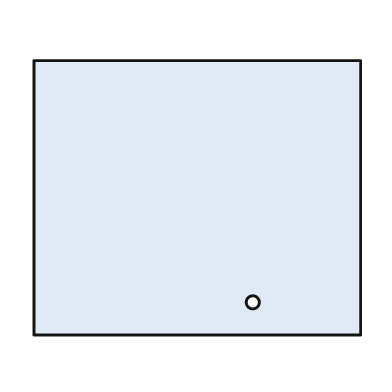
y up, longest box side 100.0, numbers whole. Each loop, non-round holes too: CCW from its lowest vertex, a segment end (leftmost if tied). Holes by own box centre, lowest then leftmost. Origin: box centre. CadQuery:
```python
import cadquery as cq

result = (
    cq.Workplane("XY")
    .moveTo(-50.0, -42.0)
    .lineTo(50.0, -42.0)
    .lineTo(50.0, 42.0)
    .lineTo(-50.0, 42.0)
    .close()
    .moveTo(17.0, -32.0)
    .circle(2.0)
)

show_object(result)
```